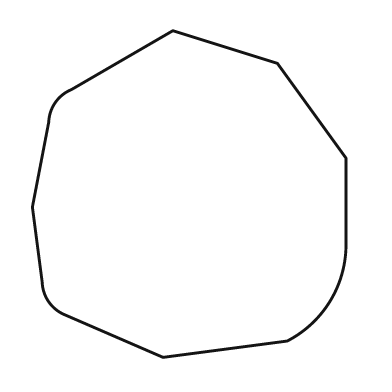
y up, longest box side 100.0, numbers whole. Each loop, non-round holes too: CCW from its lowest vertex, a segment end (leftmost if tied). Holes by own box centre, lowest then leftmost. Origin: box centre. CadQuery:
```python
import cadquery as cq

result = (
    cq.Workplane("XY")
    .moveTo(-8.0, -50.0)
    .lineTo(30.0, -45.0)
    .threePointArc((43.0, -33.0), (48.0, -16.0))
    .lineTo(48.0, 11.0)
    .lineTo(27.0, 40.0)
    .lineTo(-5.0, 50.0)
    .lineTo(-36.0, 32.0)
    .threePointArc((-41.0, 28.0), (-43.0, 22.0))
    .lineTo(-48.0, -4.0)
    .lineTo(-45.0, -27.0)
    .threePointArc((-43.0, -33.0), (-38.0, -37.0))
    .close()
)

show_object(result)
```